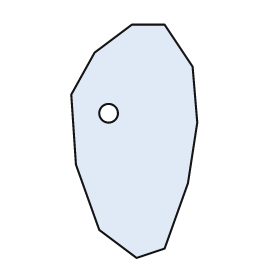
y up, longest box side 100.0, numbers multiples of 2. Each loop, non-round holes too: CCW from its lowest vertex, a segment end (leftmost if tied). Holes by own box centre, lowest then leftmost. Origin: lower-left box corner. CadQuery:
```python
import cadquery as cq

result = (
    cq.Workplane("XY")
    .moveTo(28.0, 0.0)
    .lineTo(40.0, 4.0)
    .lineTo(50.0, 32.0)
    .lineTo(54.0, 58.0)
    .lineTo(52.0, 82.0)
    .lineTo(40.0, 100.0)
    .lineTo(26.0, 100.0)
    .lineTo(10.0, 88.0)
    .lineTo(0.0, 70.0)
    .lineTo(2.0, 40.0)
    .lineTo(12.0, 12.0)
    .close()
    .moveTo(16.0, 62.0)
    .circle(4.0)
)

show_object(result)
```